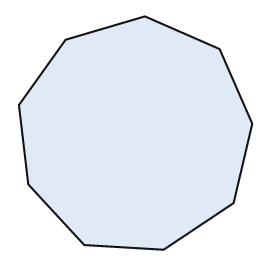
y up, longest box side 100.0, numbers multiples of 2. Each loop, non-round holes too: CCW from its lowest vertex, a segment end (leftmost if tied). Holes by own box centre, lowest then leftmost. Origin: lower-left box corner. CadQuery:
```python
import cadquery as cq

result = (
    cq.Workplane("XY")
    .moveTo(62.0, 0.0)
    .lineTo(92.0, 20.0)
    .lineTo(100.0, 54.0)
    .lineTo(86.0, 86.0)
    .lineTo(54.0, 100.0)
    .lineTo(20.0, 90.0)
    .lineTo(0.0, 62.0)
    .lineTo(4.0, 28.0)
    .lineTo(28.0, 2.0)
    .close()
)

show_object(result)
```